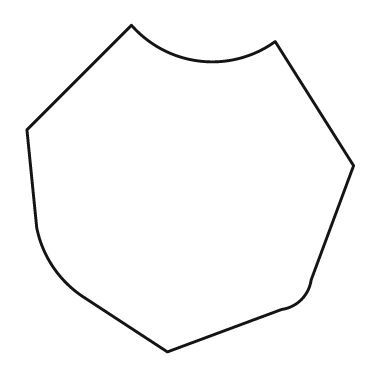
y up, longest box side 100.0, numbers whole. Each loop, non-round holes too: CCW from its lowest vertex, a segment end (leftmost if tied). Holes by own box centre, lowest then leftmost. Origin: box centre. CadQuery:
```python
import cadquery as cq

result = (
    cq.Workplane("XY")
    .moveTo(-7.0, -50.0)
    .lineTo(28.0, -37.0)
    .threePointArc((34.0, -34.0), (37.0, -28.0))
    .lineTo(50.0, 7.0)
    .lineTo(26.0, 45.0)
    .threePointArc((3.0, 39.0), (-18.0, 50.0))
    .lineTo(-50.0, 18.0)
    .lineTo(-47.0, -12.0)
    .threePointArc((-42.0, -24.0), (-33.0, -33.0))
    .close()
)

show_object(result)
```